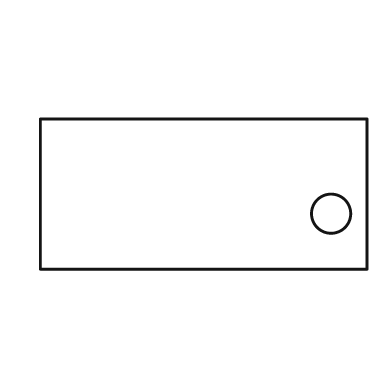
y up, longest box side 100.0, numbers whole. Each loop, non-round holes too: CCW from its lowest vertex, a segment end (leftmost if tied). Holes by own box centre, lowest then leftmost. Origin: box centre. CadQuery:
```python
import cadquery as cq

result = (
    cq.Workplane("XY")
    .moveTo(-50.0, -23.0)
    .lineTo(50.0, -23.0)
    .lineTo(50.0, 23.0)
    .lineTo(-50.0, 23.0)
    .close()
    .moveTo(39.0, -6.0)
    .circle(6.0)
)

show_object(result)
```